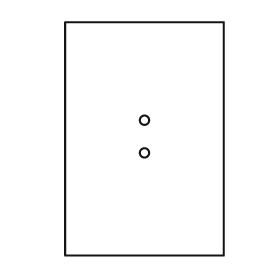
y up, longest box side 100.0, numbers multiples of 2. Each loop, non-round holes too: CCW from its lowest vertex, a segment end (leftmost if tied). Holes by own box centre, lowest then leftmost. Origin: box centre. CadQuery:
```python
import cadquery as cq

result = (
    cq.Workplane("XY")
    .moveTo(-34.0, -50.0)
    .lineTo(34.0, -50.0)
    .lineTo(34.0, 50.0)
    .lineTo(-34.0, 50.0)
    .close()
    .moveTo(0.0, -6.0)
    .circle(2.0)
    .moveTo(0.0, 8.0)
    .circle(2.0)
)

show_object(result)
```